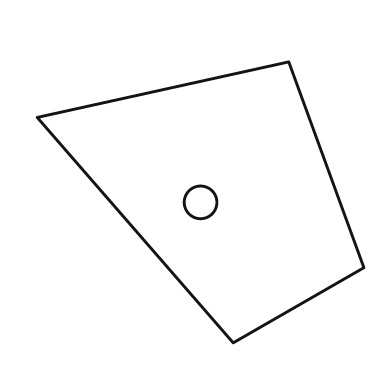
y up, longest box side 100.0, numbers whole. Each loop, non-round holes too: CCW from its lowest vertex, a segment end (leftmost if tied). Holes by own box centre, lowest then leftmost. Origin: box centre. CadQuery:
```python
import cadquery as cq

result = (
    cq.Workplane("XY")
    .moveTo(10.0, -43.0)
    .lineTo(50.0, -20.0)
    .lineTo(27.0, 43.0)
    .lineTo(-50.0, 26.0)
    .close()
    .moveTo(0.0, 0.0)
    .circle(5.0)
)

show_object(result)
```